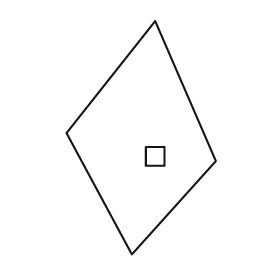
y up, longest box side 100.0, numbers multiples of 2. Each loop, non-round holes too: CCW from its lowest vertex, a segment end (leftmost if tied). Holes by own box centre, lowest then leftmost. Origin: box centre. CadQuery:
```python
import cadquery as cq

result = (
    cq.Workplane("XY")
    .moveTo(-4.0, -50.0)
    .lineTo(32.0, -10.0)
    .lineTo(6.0, 50.0)
    .lineTo(-32.0, 2.0)
    .close()
    .moveTo(2.0, -12.0)
    .lineTo(10.0, -12.0)
    .lineTo(10.0, -4.0)
    .lineTo(2.0, -4.0)
    .close()
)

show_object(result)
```